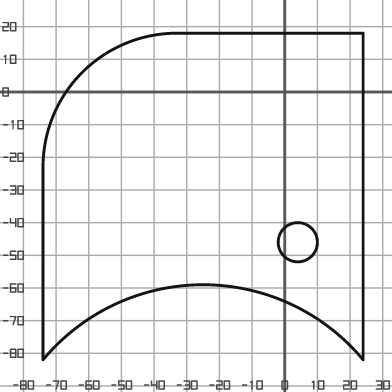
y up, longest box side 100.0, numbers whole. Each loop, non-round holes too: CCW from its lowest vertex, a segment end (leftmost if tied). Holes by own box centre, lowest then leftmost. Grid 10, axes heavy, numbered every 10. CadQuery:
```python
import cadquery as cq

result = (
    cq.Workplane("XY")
    .moveTo(-74.0, -82.0)
    .threePointArc((-25.0, -59.0), (24.0, -82.0))
    .lineTo(24.0, 18.0)
    .lineTo(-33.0, 18.0)
    .threePointArc((-62.0, 6.0), (-74.0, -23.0))
    .close()
    .moveTo(4.0, -46.0)
    .circle(6.0)
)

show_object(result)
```